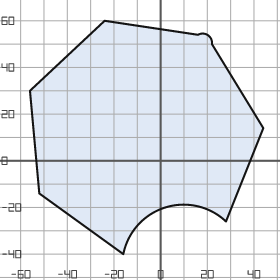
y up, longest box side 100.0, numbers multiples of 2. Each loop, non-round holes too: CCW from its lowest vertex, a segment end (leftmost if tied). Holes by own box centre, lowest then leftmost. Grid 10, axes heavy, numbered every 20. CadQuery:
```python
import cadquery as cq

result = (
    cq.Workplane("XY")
    .moveTo(-16.0, -40.0)
    .threePointArc((2.0, -20.0), (28.0, -26.0))
    .lineTo(44.0, 14.0)
    .lineTo(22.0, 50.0)
    .threePointArc((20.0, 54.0), (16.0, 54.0))
    .lineTo(-24.0, 60.0)
    .lineTo(-56.0, 30.0)
    .lineTo(-52.0, -14.0)
    .close()
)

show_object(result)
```